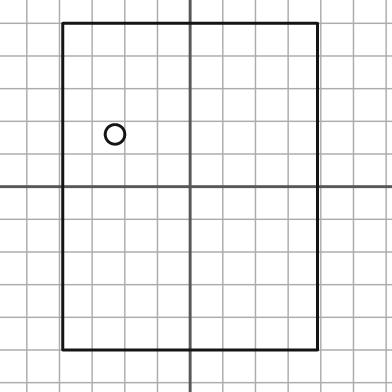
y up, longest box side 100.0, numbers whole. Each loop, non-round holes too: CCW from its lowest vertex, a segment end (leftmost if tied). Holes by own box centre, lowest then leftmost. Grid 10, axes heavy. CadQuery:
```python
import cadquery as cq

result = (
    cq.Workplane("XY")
    .moveTo(-39.0, -50.0)
    .lineTo(39.0, -50.0)
    .lineTo(39.0, 50.0)
    .lineTo(-39.0, 50.0)
    .close()
    .moveTo(-23.0, 16.0)
    .circle(3.0)
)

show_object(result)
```